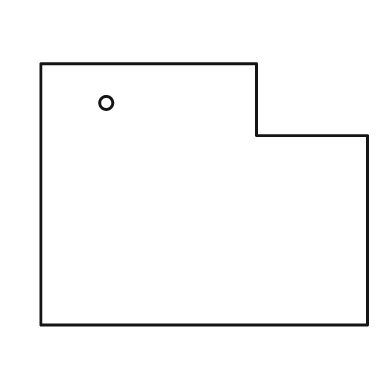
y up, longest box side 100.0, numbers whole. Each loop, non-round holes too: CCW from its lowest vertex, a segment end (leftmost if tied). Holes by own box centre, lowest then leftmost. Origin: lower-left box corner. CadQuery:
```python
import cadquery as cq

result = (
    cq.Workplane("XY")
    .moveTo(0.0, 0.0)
    .lineTo(100.0, 0.0)
    .lineTo(100.0, 58.0)
    .lineTo(66.0, 58.0)
    .lineTo(66.0, 80.0)
    .lineTo(0.0, 80.0)
    .close()
    .moveTo(20.0, 68.0)
    .circle(2.0)
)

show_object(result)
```